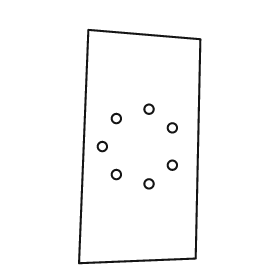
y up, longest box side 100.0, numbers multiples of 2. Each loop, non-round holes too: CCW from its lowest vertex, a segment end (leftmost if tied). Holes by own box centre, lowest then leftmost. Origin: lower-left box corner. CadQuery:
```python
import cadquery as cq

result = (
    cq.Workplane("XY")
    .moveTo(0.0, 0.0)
    .lineTo(50.0, 2.0)
    .lineTo(52.0, 96.0)
    .lineTo(4.0, 100.0)
    .close()
    .moveTo(30.0, 34.0)
    .circle(2.0)
    .moveTo(16.0, 38.0)
    .circle(2.0)
    .moveTo(40.0, 42.0)
    .circle(2.0)
    .moveTo(10.0, 50.0)
    .circle(2.0)
    .moveTo(40.0, 58.0)
    .circle(2.0)
    .moveTo(16.0, 62.0)
    .circle(2.0)
    .moveTo(30.0, 66.0)
    .circle(2.0)
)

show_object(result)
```